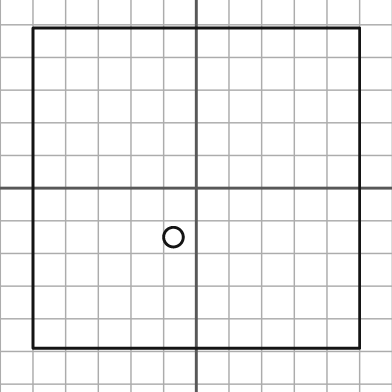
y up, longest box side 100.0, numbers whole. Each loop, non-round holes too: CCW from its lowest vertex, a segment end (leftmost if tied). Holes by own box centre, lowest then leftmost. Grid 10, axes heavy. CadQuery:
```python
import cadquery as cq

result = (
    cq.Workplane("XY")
    .moveTo(-50.0, -49.0)
    .lineTo(50.0, -49.0)
    .lineTo(50.0, 49.0)
    .lineTo(-50.0, 49.0)
    .close()
    .moveTo(-7.0, -15.0)
    .circle(3.0)
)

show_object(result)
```